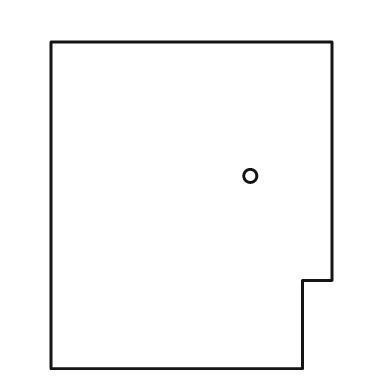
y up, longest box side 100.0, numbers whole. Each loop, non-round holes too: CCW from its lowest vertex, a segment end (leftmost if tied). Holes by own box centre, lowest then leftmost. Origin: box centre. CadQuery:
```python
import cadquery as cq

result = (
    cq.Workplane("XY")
    .moveTo(-43.0, -50.0)
    .lineTo(34.0, -50.0)
    .lineTo(34.0, -23.0)
    .lineTo(43.0, -23.0)
    .lineTo(43.0, 50.0)
    .lineTo(-43.0, 50.0)
    .close()
    .moveTo(18.0, 9.0)
    .circle(2.0)
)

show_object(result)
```